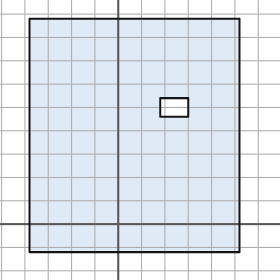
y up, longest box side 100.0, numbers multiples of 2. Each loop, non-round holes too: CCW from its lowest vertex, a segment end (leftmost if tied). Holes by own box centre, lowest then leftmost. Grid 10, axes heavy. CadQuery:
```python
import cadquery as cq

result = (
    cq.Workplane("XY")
    .moveTo(-38.0, -12.0)
    .lineTo(52.0, -12.0)
    .lineTo(52.0, 88.0)
    .lineTo(-38.0, 88.0)
    .close()
    .moveTo(18.0, 46.0)
    .lineTo(30.0, 46.0)
    .lineTo(30.0, 54.0)
    .lineTo(18.0, 54.0)
    .close()
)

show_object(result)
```